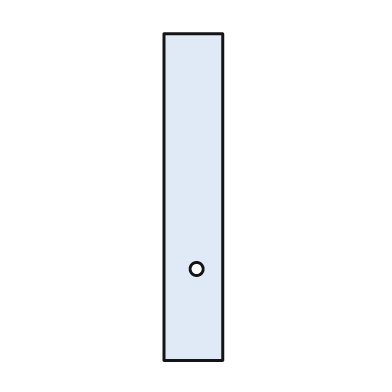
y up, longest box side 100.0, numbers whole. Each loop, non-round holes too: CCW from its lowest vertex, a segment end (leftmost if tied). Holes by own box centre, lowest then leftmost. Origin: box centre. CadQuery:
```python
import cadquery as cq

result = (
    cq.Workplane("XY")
    .moveTo(-9.0, -50.0)
    .lineTo(9.0, -50.0)
    .lineTo(9.0, 50.0)
    .lineTo(-9.0, 50.0)
    .close()
    .moveTo(1.0, -22.0)
    .circle(2.0)
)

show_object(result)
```